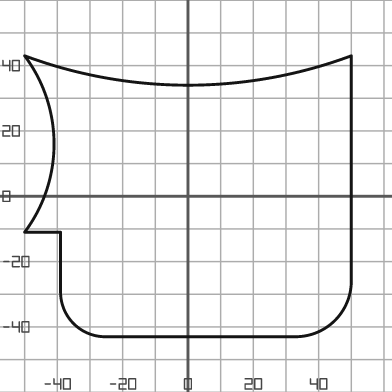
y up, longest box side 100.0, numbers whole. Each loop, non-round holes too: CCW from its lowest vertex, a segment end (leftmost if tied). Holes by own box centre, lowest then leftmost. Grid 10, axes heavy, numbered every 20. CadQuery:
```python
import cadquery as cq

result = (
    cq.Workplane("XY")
    .moveTo(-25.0, -43.0)
    .lineTo(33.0, -43.0)
    .threePointArc((45.0, -38.0), (50.0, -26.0))
    .lineTo(50.0, 43.0)
    .threePointArc((0.0, 34.0), (-50.0, 43.0))
    .threePointArc((-41.0, 16.0), (-50.0, -11.0))
    .lineTo(-39.0, -11.0)
    .lineTo(-39.0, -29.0)
    .threePointArc((-35.0, -39.0), (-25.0, -43.0))
    .close()
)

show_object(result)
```